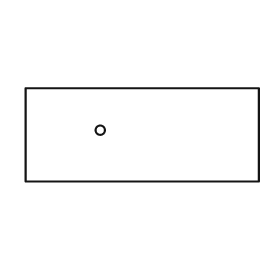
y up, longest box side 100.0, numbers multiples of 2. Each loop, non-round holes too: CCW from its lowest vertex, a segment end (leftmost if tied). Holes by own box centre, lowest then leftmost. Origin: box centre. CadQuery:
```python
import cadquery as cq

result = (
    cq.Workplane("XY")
    .moveTo(-50.0, -20.0)
    .lineTo(50.0, -20.0)
    .lineTo(50.0, 20.0)
    .lineTo(-50.0, 20.0)
    .close()
    .moveTo(-18.0, 2.0)
    .circle(2.0)
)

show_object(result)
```